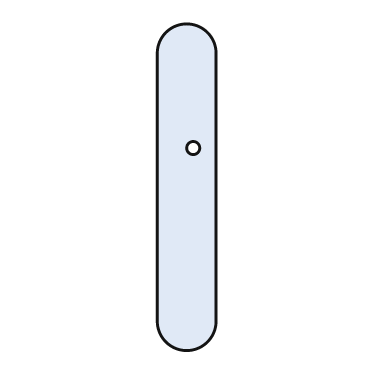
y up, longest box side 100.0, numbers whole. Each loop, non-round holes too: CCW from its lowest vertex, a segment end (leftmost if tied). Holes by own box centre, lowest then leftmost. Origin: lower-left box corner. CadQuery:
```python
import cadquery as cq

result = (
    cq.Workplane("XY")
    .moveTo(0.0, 9.0)
    .threePointArc((9.0, 0.0), (18.0, 9.0))
    .lineTo(18.0, 91.0)
    .threePointArc((9.0, 100.0), (0.0, 91.0))
    .close()
    .moveTo(11.0, 62.0)
    .circle(2.0)
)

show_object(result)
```